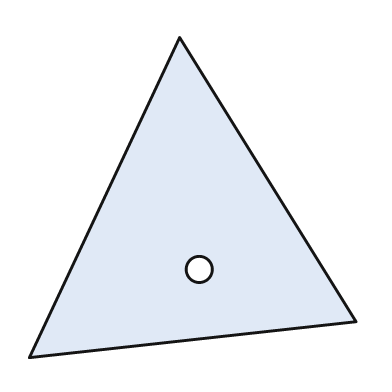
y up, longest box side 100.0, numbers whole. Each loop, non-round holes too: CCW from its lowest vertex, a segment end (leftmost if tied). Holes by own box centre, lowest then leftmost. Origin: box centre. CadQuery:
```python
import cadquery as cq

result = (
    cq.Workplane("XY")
    .moveTo(-50.0, -49.0)
    .lineTo(50.0, -38.0)
    .lineTo(-4.0, 49.0)
    .close()
    .moveTo(2.0, -22.0)
    .circle(4.0)
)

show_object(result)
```